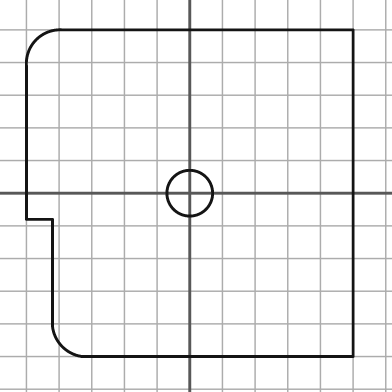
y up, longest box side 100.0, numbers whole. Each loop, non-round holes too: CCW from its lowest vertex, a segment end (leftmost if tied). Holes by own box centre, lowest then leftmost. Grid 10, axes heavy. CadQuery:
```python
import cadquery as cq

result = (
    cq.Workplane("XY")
    .moveTo(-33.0, -50.0)
    .lineTo(50.0, -50.0)
    .lineTo(50.0, 50.0)
    .lineTo(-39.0, 50.0)
    .threePointArc((-47.0, 47.0), (-50.0, 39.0))
    .lineTo(-50.0, -8.0)
    .lineTo(-42.0, -8.0)
    .lineTo(-42.0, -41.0)
    .threePointArc((-39.0, -47.0), (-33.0, -50.0))
    .close()
    .moveTo(0.0, 0.0)
    .circle(7.0)
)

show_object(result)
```